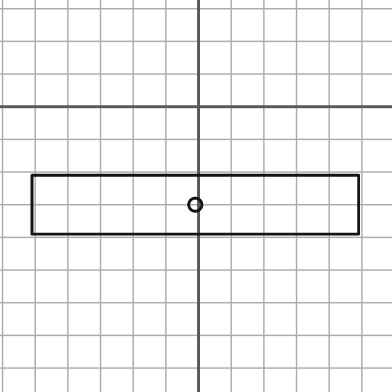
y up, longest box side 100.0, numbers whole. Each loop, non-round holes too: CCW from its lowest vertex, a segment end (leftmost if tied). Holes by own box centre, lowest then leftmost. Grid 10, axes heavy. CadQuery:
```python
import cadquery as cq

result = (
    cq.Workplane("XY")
    .moveTo(-51.0, -39.0)
    .lineTo(49.0, -39.0)
    .lineTo(49.0, -21.0)
    .lineTo(-51.0, -21.0)
    .close()
    .moveTo(-1.0, -30.0)
    .circle(2.0)
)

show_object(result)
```